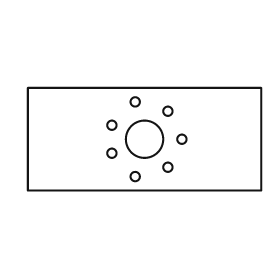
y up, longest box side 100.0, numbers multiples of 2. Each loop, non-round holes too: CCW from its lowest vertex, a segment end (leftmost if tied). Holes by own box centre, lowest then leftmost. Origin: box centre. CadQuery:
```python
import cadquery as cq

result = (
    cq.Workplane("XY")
    .moveTo(-50.0, -22.0)
    .lineTo(50.0, -22.0)
    .lineTo(50.0, 22.0)
    .lineTo(-50.0, 22.0)
    .close()
    .moveTo(-4.0, -16.0)
    .circle(2.0)
    .moveTo(10.0, -12.0)
    .circle(2.0)
    .moveTo(-14.0, -6.0)
    .circle(2.0)
    .moveTo(0.0, 0.0)
    .circle(8.0)
    .moveTo(16.0, 0.0)
    .circle(2.0)
    .moveTo(-14.0, 6.0)
    .circle(2.0)
    .moveTo(10.0, 12.0)
    .circle(2.0)
    .moveTo(-4.0, 16.0)
    .circle(2.0)
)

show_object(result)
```